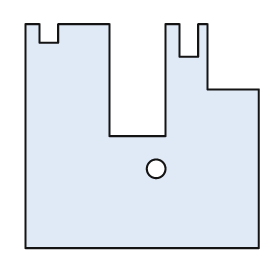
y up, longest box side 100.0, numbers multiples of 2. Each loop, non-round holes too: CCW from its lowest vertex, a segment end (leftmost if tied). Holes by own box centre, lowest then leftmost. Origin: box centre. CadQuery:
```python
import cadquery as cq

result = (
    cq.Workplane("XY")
    .moveTo(-50.0, -48.0)
    .lineTo(50.0, -48.0)
    .lineTo(50.0, 20.0)
    .lineTo(28.0, 20.0)
    .lineTo(28.0, 48.0)
    .lineTo(24.0, 48.0)
    .lineTo(24.0, 34.0)
    .lineTo(16.0, 34.0)
    .lineTo(16.0, 48.0)
    .lineTo(10.0, 48.0)
    .lineTo(10.0, 0.0)
    .lineTo(-14.0, 0.0)
    .lineTo(-14.0, 48.0)
    .lineTo(-36.0, 48.0)
    .lineTo(-36.0, 40.0)
    .lineTo(-44.0, 40.0)
    .lineTo(-44.0, 48.0)
    .lineTo(-50.0, 48.0)
    .close()
    .moveTo(6.0, -14.0)
    .circle(4.0)
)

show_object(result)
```